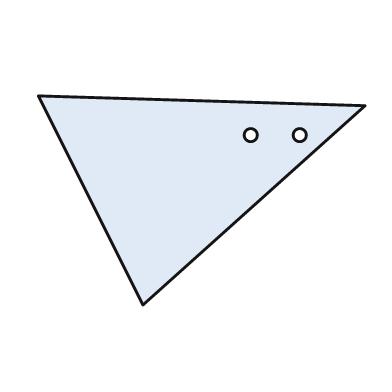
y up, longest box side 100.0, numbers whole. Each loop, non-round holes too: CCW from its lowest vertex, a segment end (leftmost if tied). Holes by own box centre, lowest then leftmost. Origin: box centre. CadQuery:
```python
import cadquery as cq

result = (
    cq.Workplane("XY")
    .moveTo(-18.0, -32.0)
    .lineTo(50.0, 29.0)
    .lineTo(-50.0, 32.0)
    .close()
    .moveTo(15.0, 20.0)
    .circle(2.0)
    .moveTo(30.0, 20.0)
    .circle(2.0)
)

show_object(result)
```